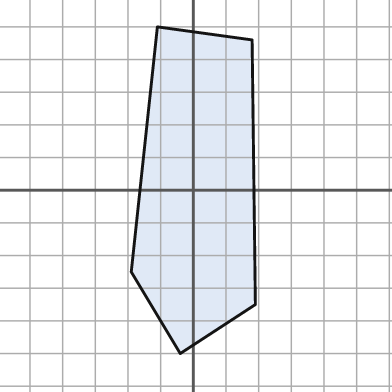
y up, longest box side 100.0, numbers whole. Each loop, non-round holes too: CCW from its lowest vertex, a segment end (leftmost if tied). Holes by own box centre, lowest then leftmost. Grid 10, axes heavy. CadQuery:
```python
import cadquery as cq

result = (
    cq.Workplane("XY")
    .moveTo(-4.0, -50.0)
    .lineTo(19.0, -35.0)
    .lineTo(18.0, 46.0)
    .lineTo(-11.0, 50.0)
    .lineTo(-19.0, -25.0)
    .close()
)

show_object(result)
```